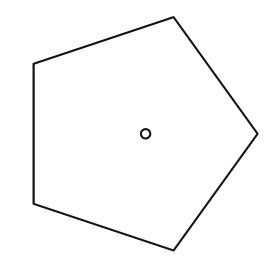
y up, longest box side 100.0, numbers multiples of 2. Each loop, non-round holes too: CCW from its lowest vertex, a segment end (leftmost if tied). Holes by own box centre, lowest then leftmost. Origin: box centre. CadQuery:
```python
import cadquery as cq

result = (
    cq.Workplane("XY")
    .moveTo(12.0, -50.0)
    .lineTo(48.0, 0.0)
    .lineTo(12.0, 50.0)
    .lineTo(-48.0, 30.0)
    .lineTo(-48.0, -30.0)
    .close()
    .moveTo(0.0, 0.0)
    .circle(2.0)
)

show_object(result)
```